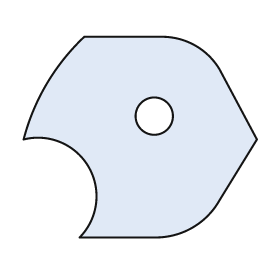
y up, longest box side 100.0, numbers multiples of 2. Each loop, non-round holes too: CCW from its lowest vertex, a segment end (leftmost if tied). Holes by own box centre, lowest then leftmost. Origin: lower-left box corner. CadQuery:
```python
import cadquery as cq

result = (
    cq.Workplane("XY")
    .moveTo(24.0, 0.0)
    .lineTo(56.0, 0.0)
    .threePointArc((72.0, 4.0), (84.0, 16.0))
    .lineTo(100.0, 42.0)
    .lineTo(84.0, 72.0)
    .threePointArc((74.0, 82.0), (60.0, 86.0))
    .lineTo(26.0, 86.0)
    .threePointArc((10.0, 66.0), (0.0, 42.0))
    .threePointArc((28.0, 30.0), (24.0, 0.0))
    .close()
    .moveTo(56.0, 52.0)
    .circle(8.0)
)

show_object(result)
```